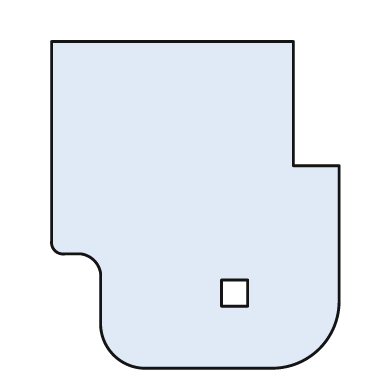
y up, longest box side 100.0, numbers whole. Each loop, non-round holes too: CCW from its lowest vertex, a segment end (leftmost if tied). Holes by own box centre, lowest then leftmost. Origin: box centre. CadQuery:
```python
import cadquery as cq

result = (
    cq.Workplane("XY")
    .moveTo(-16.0, -50.0)
    .lineTo(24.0, -50.0)
    .threePointArc((38.0, -44.0), (44.0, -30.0))
    .lineTo(44.0, 12.0)
    .lineTo(30.0, 12.0)
    .lineTo(30.0, 50.0)
    .lineTo(-44.0, 50.0)
    .lineTo(-44.0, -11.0)
    .threePointArc((-43.0, -14.0), (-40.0, -15.0))
    .lineTo(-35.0, -15.0)
    .threePointArc((-31.0, -17.0), (-29.0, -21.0))
    .lineTo(-29.0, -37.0)
    .threePointArc((-25.0, -46.0), (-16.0, -50.0))
    .close()
    .moveTo(8.0, -31.0)
    .lineTo(16.0, -31.0)
    .lineTo(16.0, -23.0)
    .lineTo(8.0, -23.0)
    .close()
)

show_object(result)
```